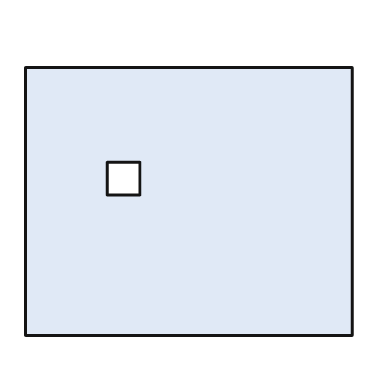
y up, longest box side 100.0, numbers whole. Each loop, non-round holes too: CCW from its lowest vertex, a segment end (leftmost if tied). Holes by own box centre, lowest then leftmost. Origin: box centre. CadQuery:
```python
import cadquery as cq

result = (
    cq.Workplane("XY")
    .moveTo(-50.0, -41.0)
    .lineTo(50.0, -41.0)
    .lineTo(50.0, 41.0)
    .lineTo(-50.0, 41.0)
    .close()
    .moveTo(-25.0, 2.0)
    .lineTo(-15.0, 2.0)
    .lineTo(-15.0, 12.0)
    .lineTo(-25.0, 12.0)
    .close()
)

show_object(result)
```